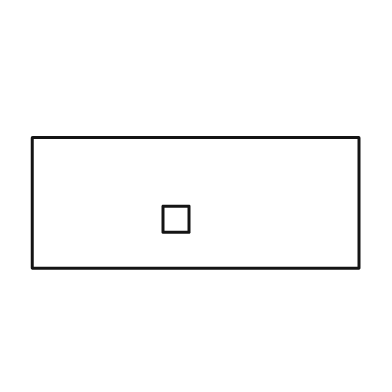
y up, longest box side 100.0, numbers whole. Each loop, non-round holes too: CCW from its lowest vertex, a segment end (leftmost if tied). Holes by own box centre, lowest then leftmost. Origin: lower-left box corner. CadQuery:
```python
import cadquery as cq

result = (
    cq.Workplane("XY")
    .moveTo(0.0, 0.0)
    .lineTo(100.0, 0.0)
    .lineTo(100.0, 40.0)
    .lineTo(0.0, 40.0)
    .close()
    .moveTo(40.0, 11.0)
    .lineTo(48.0, 11.0)
    .lineTo(48.0, 19.0)
    .lineTo(40.0, 19.0)
    .close()
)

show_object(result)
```